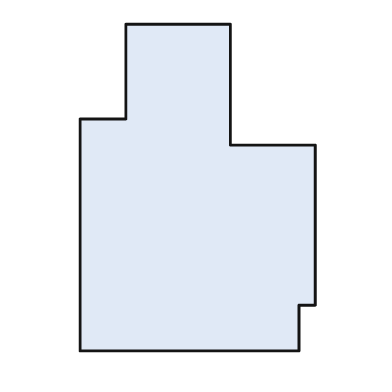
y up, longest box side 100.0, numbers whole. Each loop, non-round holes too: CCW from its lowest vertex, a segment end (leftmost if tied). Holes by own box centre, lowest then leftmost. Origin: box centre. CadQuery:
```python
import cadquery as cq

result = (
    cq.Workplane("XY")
    .moveTo(-36.0, -50.0)
    .lineTo(31.0, -50.0)
    .lineTo(31.0, -36.0)
    .lineTo(36.0, -36.0)
    .lineTo(36.0, 13.0)
    .lineTo(10.0, 13.0)
    .lineTo(10.0, 50.0)
    .lineTo(-22.0, 50.0)
    .lineTo(-22.0, 21.0)
    .lineTo(-36.0, 21.0)
    .close()
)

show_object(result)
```